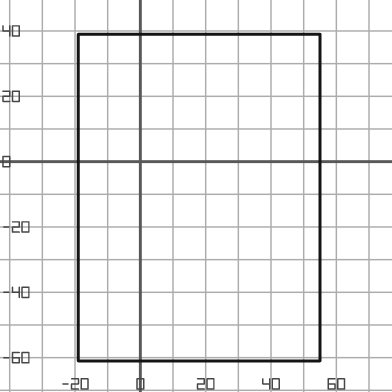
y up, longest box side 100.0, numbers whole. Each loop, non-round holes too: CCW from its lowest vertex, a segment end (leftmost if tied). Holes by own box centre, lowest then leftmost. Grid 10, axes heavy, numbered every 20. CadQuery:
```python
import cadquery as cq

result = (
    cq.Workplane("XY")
    .moveTo(-19.0, -61.0)
    .lineTo(55.0, -61.0)
    .lineTo(55.0, 39.0)
    .lineTo(-19.0, 39.0)
    .close()
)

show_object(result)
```